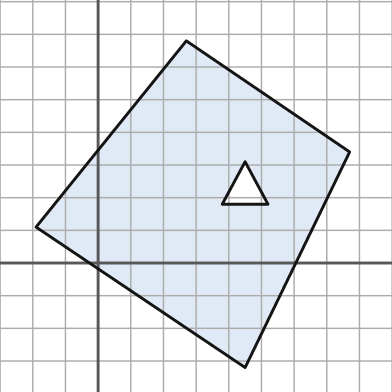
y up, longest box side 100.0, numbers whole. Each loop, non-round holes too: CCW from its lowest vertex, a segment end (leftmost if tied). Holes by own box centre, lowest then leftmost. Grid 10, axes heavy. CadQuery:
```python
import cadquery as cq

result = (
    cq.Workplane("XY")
    .moveTo(45.0, -32.0)
    .lineTo(77.0, 34.0)
    .lineTo(27.0, 68.0)
    .lineTo(-19.0, 11.0)
    .close()
    .moveTo(38.0, 18.0)
    .lineTo(52.0, 18.0)
    .lineTo(45.0, 31.0)
    .close()
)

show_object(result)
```